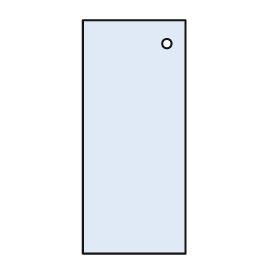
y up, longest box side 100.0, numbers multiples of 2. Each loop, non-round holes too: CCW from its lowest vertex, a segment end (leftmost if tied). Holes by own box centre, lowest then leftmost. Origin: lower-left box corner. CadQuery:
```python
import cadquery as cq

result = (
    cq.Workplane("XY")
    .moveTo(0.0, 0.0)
    .lineTo(44.0, 0.0)
    .lineTo(44.0, 100.0)
    .lineTo(0.0, 100.0)
    .close()
    .moveTo(36.0, 90.0)
    .circle(2.0)
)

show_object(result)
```